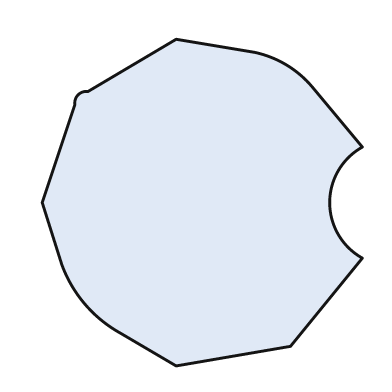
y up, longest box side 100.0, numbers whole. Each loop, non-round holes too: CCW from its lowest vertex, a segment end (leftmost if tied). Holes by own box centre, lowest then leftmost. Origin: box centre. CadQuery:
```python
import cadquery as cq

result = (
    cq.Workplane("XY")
    .moveTo(-8.0, -50.0)
    .lineTo(27.0, -44.0)
    .lineTo(49.0, -17.0)
    .threePointArc((39.0, 0.0), (49.0, 17.0))
    .lineTo(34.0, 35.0)
    .threePointArc((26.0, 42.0), (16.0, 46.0))
    .lineTo(-8.0, 50.0)
    .lineTo(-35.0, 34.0)
    .threePointArc((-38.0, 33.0), (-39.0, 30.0))
    .lineTo(-49.0, 0.0)
    .lineTo(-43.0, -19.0)
    .threePointArc((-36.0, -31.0), (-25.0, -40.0))
    .close()
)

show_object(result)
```